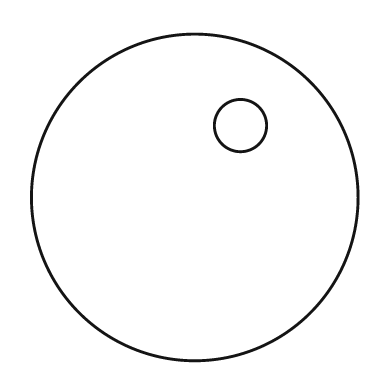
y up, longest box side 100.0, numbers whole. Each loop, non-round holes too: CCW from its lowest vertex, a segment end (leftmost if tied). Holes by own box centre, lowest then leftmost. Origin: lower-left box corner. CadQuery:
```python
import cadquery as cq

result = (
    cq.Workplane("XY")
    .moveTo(50.0, 50.0)
    .circle(50.0)
    .moveTo(64.0, 72.0)
    .circle(8.0)
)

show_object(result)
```